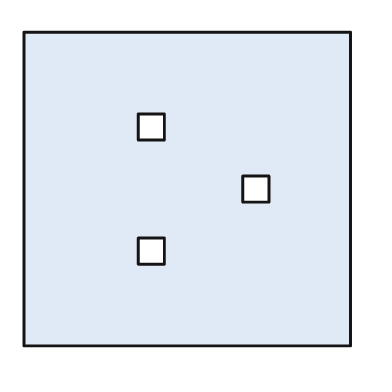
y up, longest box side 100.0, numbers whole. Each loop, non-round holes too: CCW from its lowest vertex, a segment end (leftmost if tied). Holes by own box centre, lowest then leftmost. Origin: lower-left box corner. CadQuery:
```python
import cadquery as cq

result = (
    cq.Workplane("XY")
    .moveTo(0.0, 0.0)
    .lineTo(100.0, 0.0)
    .lineTo(100.0, 96.0)
    .lineTo(0.0, 96.0)
    .close()
    .moveTo(35.0, 25.0)
    .lineTo(43.0, 25.0)
    .lineTo(43.0, 33.0)
    .lineTo(35.0, 33.0)
    .close()
    .moveTo(67.0, 44.0)
    .lineTo(75.0, 44.0)
    .lineTo(75.0, 52.0)
    .lineTo(67.0, 52.0)
    .close()
    .moveTo(35.0, 63.0)
    .lineTo(43.0, 63.0)
    .lineTo(43.0, 71.0)
    .lineTo(35.0, 71.0)
    .close()
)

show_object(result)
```